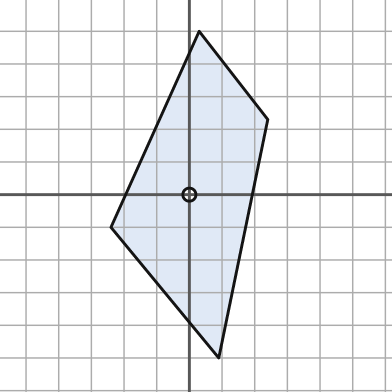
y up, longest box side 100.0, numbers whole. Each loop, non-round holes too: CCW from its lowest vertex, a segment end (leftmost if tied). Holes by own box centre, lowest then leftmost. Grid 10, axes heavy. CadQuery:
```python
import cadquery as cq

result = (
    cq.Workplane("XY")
    .moveTo(9.0, -50.0)
    .lineTo(24.0, 23.0)
    .lineTo(3.0, 50.0)
    .lineTo(-24.0, -10.0)
    .close()
    .moveTo(0.0, 0.0)
    .circle(2.0)
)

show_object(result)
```